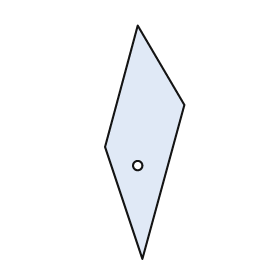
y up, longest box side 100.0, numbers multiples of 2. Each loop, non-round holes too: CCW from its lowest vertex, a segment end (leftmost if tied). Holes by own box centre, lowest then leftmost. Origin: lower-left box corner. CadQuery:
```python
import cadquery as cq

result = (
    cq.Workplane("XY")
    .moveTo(16.0, 0.0)
    .lineTo(34.0, 66.0)
    .lineTo(14.0, 100.0)
    .lineTo(0.0, 48.0)
    .close()
    .moveTo(14.0, 40.0)
    .circle(2.0)
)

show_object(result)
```